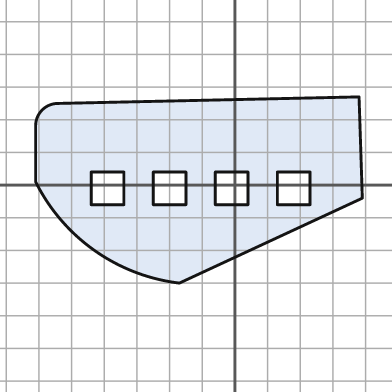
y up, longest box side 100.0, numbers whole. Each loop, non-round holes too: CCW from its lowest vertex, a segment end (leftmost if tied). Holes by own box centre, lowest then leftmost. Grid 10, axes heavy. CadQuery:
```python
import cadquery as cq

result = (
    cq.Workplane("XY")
    .moveTo(-17.0, -30.0)
    .lineTo(39.0, -4.0)
    .lineTo(38.0, 27.0)
    .lineTo(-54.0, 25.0)
    .threePointArc((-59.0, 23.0), (-61.0, 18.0))
    .lineTo(-61.0, 1.0)
    .threePointArc((-43.0, -20.0), (-17.0, -30.0))
    .close()
    .moveTo(-44.0, -6.0)
    .lineTo(-34.0, -6.0)
    .lineTo(-34.0, 4.0)
    .lineTo(-44.0, 4.0)
    .close()
    .moveTo(-25.0, -6.0)
    .lineTo(-15.0, -6.0)
    .lineTo(-15.0, 4.0)
    .lineTo(-25.0, 4.0)
    .close()
    .moveTo(-6.0, -6.0)
    .lineTo(4.0, -6.0)
    .lineTo(4.0, 4.0)
    .lineTo(-6.0, 4.0)
    .close()
    .moveTo(13.0, -6.0)
    .lineTo(23.0, -6.0)
    .lineTo(23.0, 4.0)
    .lineTo(13.0, 4.0)
    .close()
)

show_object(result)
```